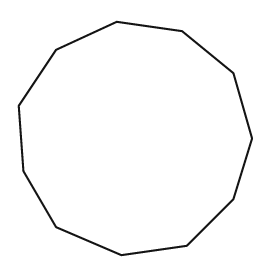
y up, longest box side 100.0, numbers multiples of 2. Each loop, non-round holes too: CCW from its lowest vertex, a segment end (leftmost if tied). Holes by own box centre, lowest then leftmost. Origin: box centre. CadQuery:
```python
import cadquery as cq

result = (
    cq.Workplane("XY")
    .moveTo(-6.0, -50.0)
    .lineTo(22.0, -46.0)
    .lineTo(42.0, -26.0)
    .lineTo(50.0, 0.0)
    .lineTo(42.0, 28.0)
    .lineTo(20.0, 46.0)
    .lineTo(-8.0, 50.0)
    .lineTo(-34.0, 38.0)
    .lineTo(-50.0, 14.0)
    .lineTo(-48.0, -14.0)
    .lineTo(-34.0, -38.0)
    .close()
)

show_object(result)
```